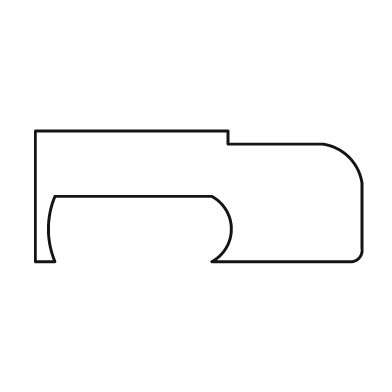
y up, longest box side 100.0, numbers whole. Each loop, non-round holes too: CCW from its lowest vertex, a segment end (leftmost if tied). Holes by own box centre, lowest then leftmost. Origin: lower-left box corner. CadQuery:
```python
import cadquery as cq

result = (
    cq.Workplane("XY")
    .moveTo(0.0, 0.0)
    .lineTo(6.0, 0.0)
    .threePointArc((4.0, 10.0), (6.0, 20.0))
    .lineTo(54.0, 20.0)
    .threePointArc((60.0, 10.0), (54.0, 0.0))
    .lineTo(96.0, 0.0)
    .threePointArc((99.0, 1.0), (100.0, 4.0))
    .lineTo(100.0, 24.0)
    .threePointArc((96.0, 32.0), (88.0, 36.0))
    .lineTo(59.0, 36.0)
    .lineTo(59.0, 40.0)
    .lineTo(0.0, 40.0)
    .close()
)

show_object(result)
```